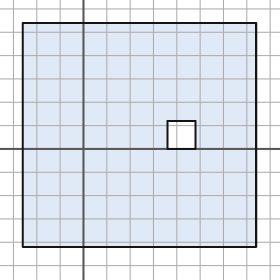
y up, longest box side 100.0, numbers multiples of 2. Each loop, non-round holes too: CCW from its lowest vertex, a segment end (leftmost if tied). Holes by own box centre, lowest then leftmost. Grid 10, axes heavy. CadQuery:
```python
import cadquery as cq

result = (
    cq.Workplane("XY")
    .moveTo(-26.0, -42.0)
    .lineTo(74.0, -42.0)
    .lineTo(74.0, 54.0)
    .lineTo(-26.0, 54.0)
    .close()
    .moveTo(36.0, 0.0)
    .lineTo(48.0, 0.0)
    .lineTo(48.0, 12.0)
    .lineTo(36.0, 12.0)
    .close()
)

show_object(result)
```